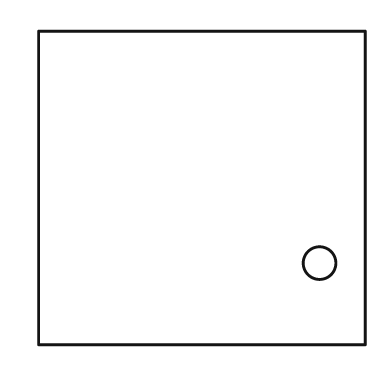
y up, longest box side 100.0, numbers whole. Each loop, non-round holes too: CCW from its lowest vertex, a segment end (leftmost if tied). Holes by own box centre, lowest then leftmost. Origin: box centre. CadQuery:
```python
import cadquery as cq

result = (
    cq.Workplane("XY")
    .moveTo(-50.0, -48.0)
    .lineTo(50.0, -48.0)
    .lineTo(50.0, 48.0)
    .lineTo(-50.0, 48.0)
    .close()
    .moveTo(36.0, -23.0)
    .circle(5.0)
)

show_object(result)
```